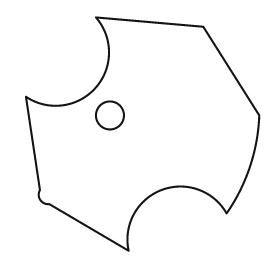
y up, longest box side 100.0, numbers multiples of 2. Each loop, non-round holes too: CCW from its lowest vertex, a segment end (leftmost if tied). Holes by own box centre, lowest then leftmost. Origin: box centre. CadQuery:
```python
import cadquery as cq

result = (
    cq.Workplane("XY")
    .moveTo(-6.0, -50.0)
    .threePointArc((8.0, -24.0), (36.0, -34.0))
    .threePointArc((46.0, -14.0), (50.0, 8.0))
    .lineTo(26.0, 46.0)
    .lineTo(-20.0, 50.0)
    .threePointArc((-20.0, 20.0), (-50.0, 16.0))
    .lineTo(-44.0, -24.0)
    .threePointArc((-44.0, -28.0), (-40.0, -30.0))
    .close()
    .moveTo(-14.0, 8.0)
    .circle(6.0)
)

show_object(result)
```